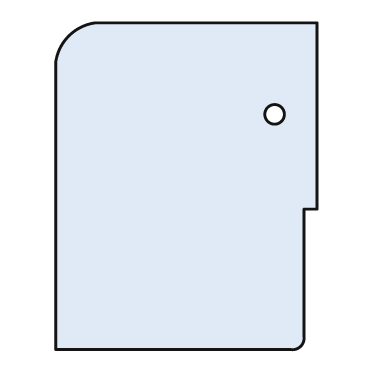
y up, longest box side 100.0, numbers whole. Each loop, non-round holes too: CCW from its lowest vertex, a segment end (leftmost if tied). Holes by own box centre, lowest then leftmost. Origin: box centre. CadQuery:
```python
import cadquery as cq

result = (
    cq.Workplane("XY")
    .moveTo(-40.0, -50.0)
    .lineTo(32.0, -50.0)
    .threePointArc((35.0, -49.0), (36.0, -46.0))
    .lineTo(36.0, -7.0)
    .lineTo(40.0, -7.0)
    .lineTo(40.0, 50.0)
    .lineTo(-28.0, 50.0)
    .threePointArc((-36.0, 46.0), (-40.0, 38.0))
    .close()
    .moveTo(27.0, 22.0)
    .circle(3.0)
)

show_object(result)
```